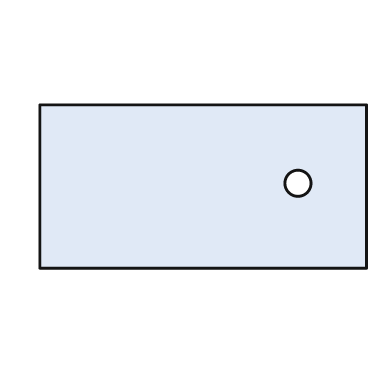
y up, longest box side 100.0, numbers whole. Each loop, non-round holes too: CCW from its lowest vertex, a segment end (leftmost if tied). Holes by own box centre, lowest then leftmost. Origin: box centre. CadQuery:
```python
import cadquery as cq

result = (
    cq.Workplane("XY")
    .moveTo(-50.0, -25.0)
    .lineTo(50.0, -25.0)
    .lineTo(50.0, 25.0)
    .lineTo(-50.0, 25.0)
    .close()
    .moveTo(29.0, 1.0)
    .circle(4.0)
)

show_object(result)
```